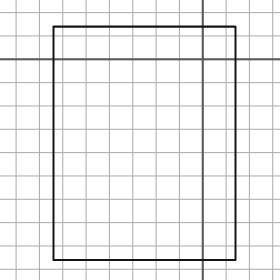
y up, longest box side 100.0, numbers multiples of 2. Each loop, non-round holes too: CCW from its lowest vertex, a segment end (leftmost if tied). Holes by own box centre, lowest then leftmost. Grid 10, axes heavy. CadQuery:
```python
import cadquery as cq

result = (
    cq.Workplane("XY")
    .moveTo(-64.0, -86.0)
    .lineTo(14.0, -86.0)
    .lineTo(14.0, 14.0)
    .lineTo(-64.0, 14.0)
    .close()
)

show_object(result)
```